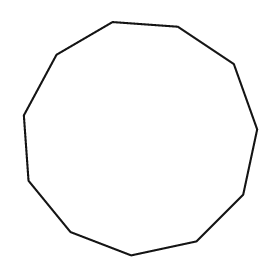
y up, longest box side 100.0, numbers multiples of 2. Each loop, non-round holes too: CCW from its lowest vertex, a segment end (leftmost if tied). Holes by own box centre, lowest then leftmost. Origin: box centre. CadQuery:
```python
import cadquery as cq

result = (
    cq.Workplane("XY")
    .moveTo(-4.0, -50.0)
    .lineTo(24.0, -44.0)
    .lineTo(44.0, -24.0)
    .lineTo(50.0, 4.0)
    .lineTo(40.0, 32.0)
    .lineTo(16.0, 48.0)
    .lineTo(-12.0, 50.0)
    .lineTo(-36.0, 36.0)
    .lineTo(-50.0, 10.0)
    .lineTo(-48.0, -18.0)
    .lineTo(-30.0, -40.0)
    .close()
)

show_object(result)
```